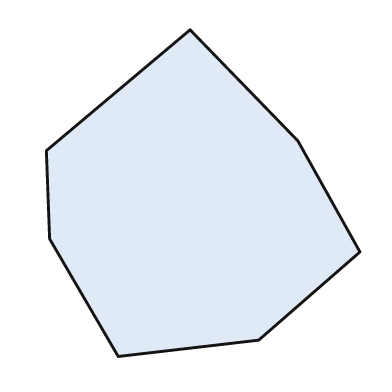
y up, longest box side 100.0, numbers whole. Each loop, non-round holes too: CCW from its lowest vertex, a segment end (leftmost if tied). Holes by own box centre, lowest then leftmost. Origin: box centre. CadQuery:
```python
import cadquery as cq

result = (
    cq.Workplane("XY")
    .moveTo(-26.0, -50.0)
    .lineTo(17.0, -45.0)
    .lineTo(48.0, -18.0)
    .lineTo(29.0, 16.0)
    .lineTo(-4.0, 50.0)
    .lineTo(-48.0, 13.0)
    .lineTo(-47.0, -14.0)
    .close()
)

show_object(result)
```